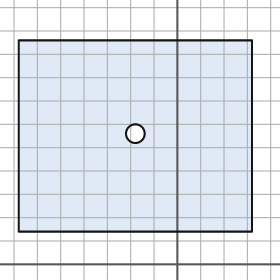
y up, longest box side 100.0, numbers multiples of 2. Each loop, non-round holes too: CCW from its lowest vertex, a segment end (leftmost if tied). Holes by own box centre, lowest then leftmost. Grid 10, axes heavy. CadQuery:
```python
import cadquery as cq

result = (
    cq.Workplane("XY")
    .moveTo(-68.0, 14.0)
    .lineTo(32.0, 14.0)
    .lineTo(32.0, 96.0)
    .lineTo(-68.0, 96.0)
    .close()
    .moveTo(-18.0, 56.0)
    .circle(4.0)
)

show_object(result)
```